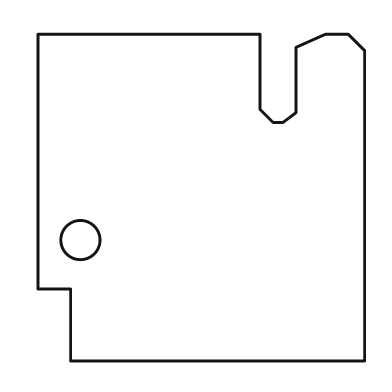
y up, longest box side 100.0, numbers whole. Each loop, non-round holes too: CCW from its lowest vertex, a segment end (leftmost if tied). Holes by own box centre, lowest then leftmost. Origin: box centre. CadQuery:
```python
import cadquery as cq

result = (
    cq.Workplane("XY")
    .moveTo(-40.0, -50.0)
    .lineTo(50.0, -50.0)
    .lineTo(50.0, 45.0)
    .lineTo(45.0, 50.0)
    .lineTo(38.0, 50.0)
    .lineTo(29.0, 46.0)
    .lineTo(29.0, 26.0)
    .lineTo(25.0, 23.0)
    .lineTo(22.0, 23.0)
    .lineTo(18.0, 27.0)
    .lineTo(18.0, 50.0)
    .lineTo(-50.0, 50.0)
    .lineTo(-50.0, -28.0)
    .lineTo(-40.0, -28.0)
    .close()
    .moveTo(-37.0, -13.0)
    .circle(6.0)
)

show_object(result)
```